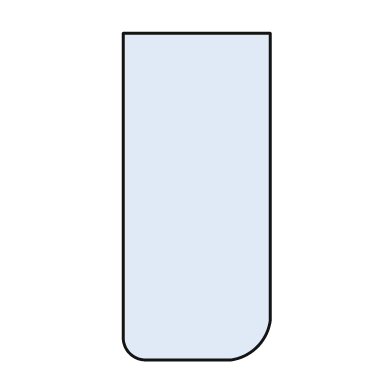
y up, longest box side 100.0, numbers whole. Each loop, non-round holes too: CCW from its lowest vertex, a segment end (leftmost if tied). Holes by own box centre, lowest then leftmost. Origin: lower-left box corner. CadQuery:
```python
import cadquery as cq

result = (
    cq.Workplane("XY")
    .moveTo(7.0, 0.0)
    .lineTo(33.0, 0.0)
    .threePointArc((41.0, 4.0), (45.0, 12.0))
    .lineTo(45.0, 100.0)
    .lineTo(0.0, 100.0)
    .lineTo(0.0, 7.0)
    .threePointArc((2.0, 2.0), (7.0, 0.0))
    .close()
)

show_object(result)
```